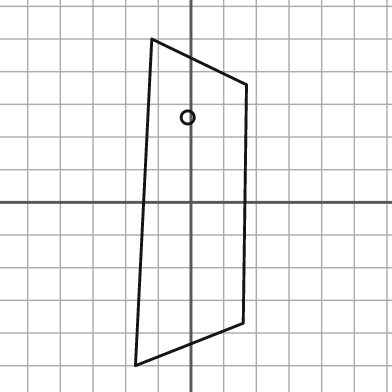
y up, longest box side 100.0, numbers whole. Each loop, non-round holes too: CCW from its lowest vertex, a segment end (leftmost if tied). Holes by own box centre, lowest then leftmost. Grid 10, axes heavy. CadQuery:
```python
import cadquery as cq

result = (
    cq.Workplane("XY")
    .moveTo(-17.0, -50.0)
    .lineTo(16.0, -37.0)
    .lineTo(17.0, 36.0)
    .lineTo(-12.0, 50.0)
    .close()
    .moveTo(-1.0, 26.0)
    .circle(2.0)
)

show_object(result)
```